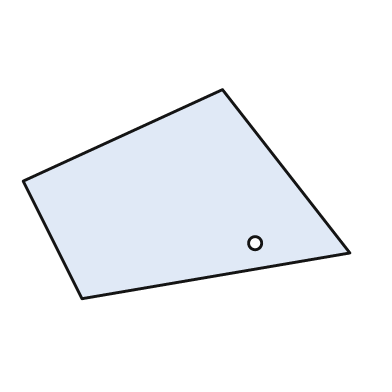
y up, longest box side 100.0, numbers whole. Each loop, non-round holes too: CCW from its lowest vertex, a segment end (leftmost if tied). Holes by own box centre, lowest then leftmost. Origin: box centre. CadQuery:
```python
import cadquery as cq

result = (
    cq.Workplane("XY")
    .moveTo(-32.0, -32.0)
    .lineTo(50.0, -18.0)
    .lineTo(11.0, 32.0)
    .lineTo(-50.0, 4.0)
    .close()
    .moveTo(21.0, -15.0)
    .circle(2.0)
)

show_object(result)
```